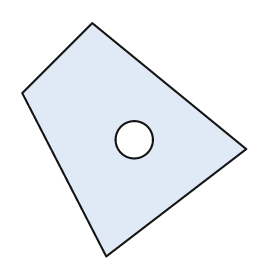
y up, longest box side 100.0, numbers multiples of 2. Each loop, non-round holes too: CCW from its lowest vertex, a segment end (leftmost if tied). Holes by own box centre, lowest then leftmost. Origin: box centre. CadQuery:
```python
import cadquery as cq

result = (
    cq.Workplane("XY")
    .moveTo(-12.0, -50.0)
    .lineTo(48.0, -4.0)
    .lineTo(-18.0, 50.0)
    .lineTo(-48.0, 20.0)
    .close()
    .moveTo(0.0, 0.0)
    .circle(8.0)
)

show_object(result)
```